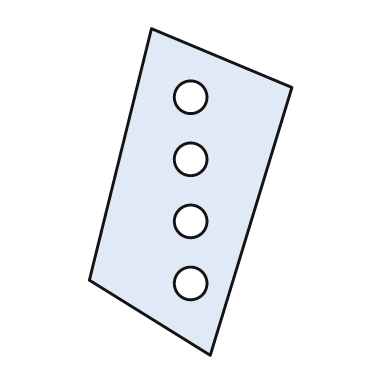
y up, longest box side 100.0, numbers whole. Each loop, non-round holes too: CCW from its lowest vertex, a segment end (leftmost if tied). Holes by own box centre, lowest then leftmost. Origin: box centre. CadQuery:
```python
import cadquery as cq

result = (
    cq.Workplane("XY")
    .moveTo(6.0, -50.0)
    .lineTo(31.0, 32.0)
    .lineTo(-12.0, 50.0)
    .lineTo(-31.0, -27.0)
    .close()
    .moveTo(0.0, -28.0)
    .circle(5.0)
    .moveTo(0.0, -9.0)
    .circle(5.0)
    .moveTo(0.0, 10.0)
    .circle(5.0)
    .moveTo(0.0, 29.0)
    .circle(5.0)
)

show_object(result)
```